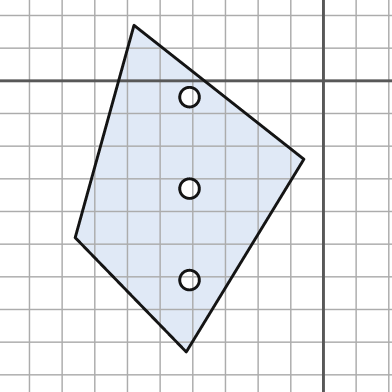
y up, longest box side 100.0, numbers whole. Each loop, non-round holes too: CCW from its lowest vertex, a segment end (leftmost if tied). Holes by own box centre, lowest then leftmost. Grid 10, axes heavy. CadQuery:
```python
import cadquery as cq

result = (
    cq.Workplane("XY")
    .moveTo(-42.0, -83.0)
    .lineTo(-6.0, -24.0)
    .lineTo(-58.0, 17.0)
    .lineTo(-76.0, -48.0)
    .close()
    .moveTo(-41.0, -61.0)
    .circle(3.0)
    .moveTo(-41.0, -33.0)
    .circle(3.0)
    .moveTo(-41.0, -5.0)
    .circle(3.0)
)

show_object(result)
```